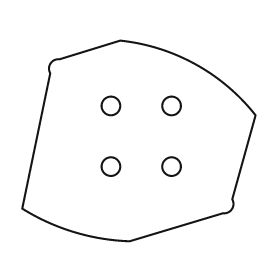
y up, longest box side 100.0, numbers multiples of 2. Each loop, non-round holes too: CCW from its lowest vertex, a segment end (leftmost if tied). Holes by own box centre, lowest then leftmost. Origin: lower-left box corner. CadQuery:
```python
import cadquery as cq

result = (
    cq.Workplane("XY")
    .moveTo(46.0, 0.0)
    .lineTo(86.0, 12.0)
    .threePointArc((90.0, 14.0), (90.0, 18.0))
    .lineTo(100.0, 54.0)
    .threePointArc((74.0, 76.0), (42.0, 86.0))
    .lineTo(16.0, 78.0)
    .threePointArc((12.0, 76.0), (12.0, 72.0))
    .lineTo(0.0, 14.0)
    .threePointArc((22.0, 4.0), (46.0, 0.0))
    .close()
    .moveTo(38.0, 32.0)
    .circle(4.0)
    .moveTo(64.0, 32.0)
    .circle(4.0)
    .moveTo(38.0, 58.0)
    .circle(4.0)
    .moveTo(64.0, 58.0)
    .circle(4.0)
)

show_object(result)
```